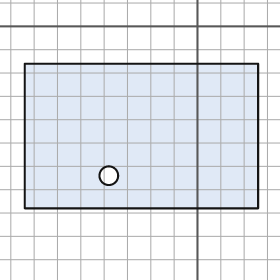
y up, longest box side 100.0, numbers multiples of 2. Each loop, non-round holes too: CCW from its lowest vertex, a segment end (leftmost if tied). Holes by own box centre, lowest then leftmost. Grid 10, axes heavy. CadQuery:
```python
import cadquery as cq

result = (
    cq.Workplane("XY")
    .moveTo(-74.0, -78.0)
    .lineTo(26.0, -78.0)
    .lineTo(26.0, -16.0)
    .lineTo(-74.0, -16.0)
    .close()
    .moveTo(-38.0, -64.0)
    .circle(4.0)
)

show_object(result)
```